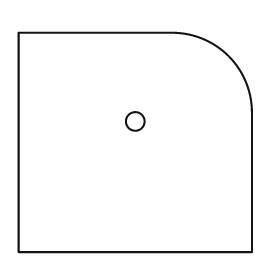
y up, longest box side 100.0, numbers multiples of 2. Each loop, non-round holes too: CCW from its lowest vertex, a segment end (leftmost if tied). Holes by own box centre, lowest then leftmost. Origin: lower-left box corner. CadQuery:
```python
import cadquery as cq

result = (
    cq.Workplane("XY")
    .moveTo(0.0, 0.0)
    .lineTo(100.0, 0.0)
    .lineTo(100.0, 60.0)
    .threePointArc((90.0, 84.0), (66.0, 94.0))
    .lineTo(0.0, 94.0)
    .close()
    .moveTo(50.0, 56.0)
    .circle(4.0)
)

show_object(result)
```